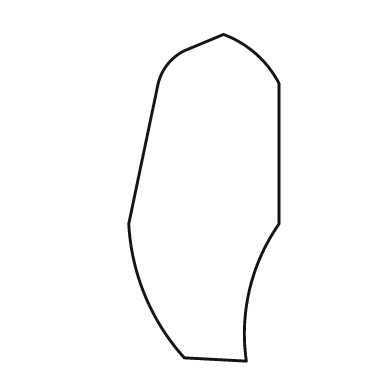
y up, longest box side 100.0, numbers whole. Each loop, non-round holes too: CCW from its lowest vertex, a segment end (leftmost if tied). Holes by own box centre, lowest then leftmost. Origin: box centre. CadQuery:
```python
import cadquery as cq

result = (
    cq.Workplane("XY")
    .moveTo(13.0, -50.0)
    .threePointArc((14.0, -28.0), (23.0, -8.0))
    .lineTo(23.0, 35.0)
    .threePointArc((16.0, 44.0), (6.0, 50.0))
    .lineTo(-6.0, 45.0)
    .threePointArc((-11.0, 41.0), (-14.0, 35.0))
    .lineTo(-23.0, -8.0)
    .threePointArc((-18.0, -30.0), (-6.0, -49.0))
    .close()
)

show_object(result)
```